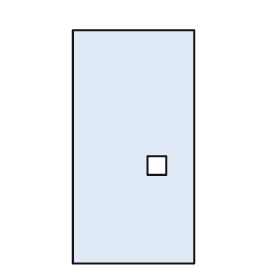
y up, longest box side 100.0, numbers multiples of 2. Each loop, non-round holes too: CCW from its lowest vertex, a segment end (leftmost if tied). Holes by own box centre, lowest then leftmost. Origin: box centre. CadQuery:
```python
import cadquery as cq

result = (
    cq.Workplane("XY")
    .moveTo(-26.0, -50.0)
    .lineTo(26.0, -50.0)
    .lineTo(26.0, 50.0)
    .lineTo(-26.0, 50.0)
    .close()
    .moveTo(6.0, -12.0)
    .lineTo(14.0, -12.0)
    .lineTo(14.0, -4.0)
    .lineTo(6.0, -4.0)
    .close()
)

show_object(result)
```